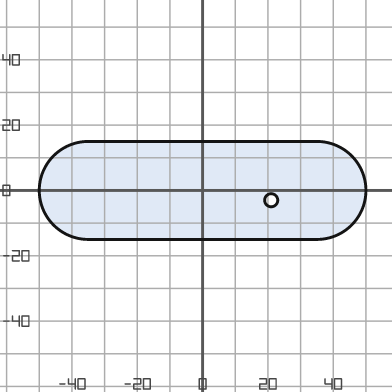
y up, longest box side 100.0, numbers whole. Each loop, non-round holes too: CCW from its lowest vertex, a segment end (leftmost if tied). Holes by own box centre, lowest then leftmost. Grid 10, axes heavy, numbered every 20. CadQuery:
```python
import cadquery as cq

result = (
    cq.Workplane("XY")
    .moveTo(-35.0, -15.0)
    .lineTo(35.0, -15.0)
    .threePointArc((50.0, 0.0), (35.0, 15.0))
    .lineTo(-35.0, 15.0)
    .threePointArc((-50.0, 0.0), (-35.0, -15.0))
    .close()
    .moveTo(21.0, -3.0)
    .circle(2.0)
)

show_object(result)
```